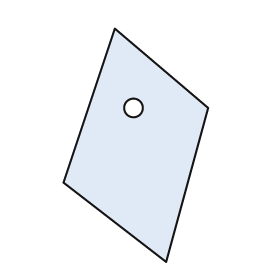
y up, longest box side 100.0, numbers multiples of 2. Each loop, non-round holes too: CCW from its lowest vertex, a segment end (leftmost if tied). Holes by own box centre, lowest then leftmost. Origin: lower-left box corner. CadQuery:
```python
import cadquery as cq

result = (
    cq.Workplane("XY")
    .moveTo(44.0, 0.0)
    .lineTo(62.0, 66.0)
    .lineTo(22.0, 100.0)
    .lineTo(0.0, 34.0)
    .close()
    .moveTo(30.0, 66.0)
    .circle(4.0)
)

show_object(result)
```